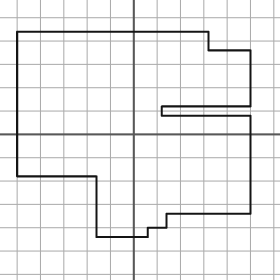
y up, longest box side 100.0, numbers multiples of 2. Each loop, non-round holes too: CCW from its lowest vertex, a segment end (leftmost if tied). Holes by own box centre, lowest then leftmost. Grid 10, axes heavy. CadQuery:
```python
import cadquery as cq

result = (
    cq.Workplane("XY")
    .moveTo(-16.0, -44.0)
    .lineTo(6.0, -44.0)
    .lineTo(6.0, -40.0)
    .lineTo(14.0, -40.0)
    .lineTo(14.0, -34.0)
    .lineTo(50.0, -34.0)
    .lineTo(50.0, 8.0)
    .lineTo(12.0, 8.0)
    .lineTo(12.0, 12.0)
    .lineTo(50.0, 12.0)
    .lineTo(50.0, 36.0)
    .lineTo(32.0, 36.0)
    .lineTo(32.0, 44.0)
    .lineTo(-50.0, 44.0)
    .lineTo(-50.0, -18.0)
    .lineTo(-16.0, -18.0)
    .close()
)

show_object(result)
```